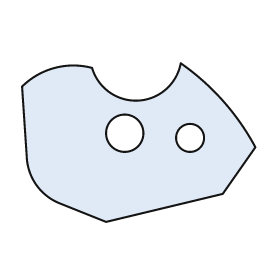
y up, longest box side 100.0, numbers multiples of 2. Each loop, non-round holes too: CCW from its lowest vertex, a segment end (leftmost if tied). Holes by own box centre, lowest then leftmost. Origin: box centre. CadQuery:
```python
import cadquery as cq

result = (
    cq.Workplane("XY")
    .moveTo(-14.0, -34.0)
    .lineTo(36.0, -22.0)
    .lineTo(50.0, -2.0)
    .threePointArc((36.0, 18.0), (18.0, 34.0))
    .threePointArc((0.0, 18.0), (-20.0, 32.0))
    .threePointArc((-36.0, 32.0), (-50.0, 24.0))
    .lineTo(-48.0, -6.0)
    .threePointArc((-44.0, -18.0), (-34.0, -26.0))
    .close()
    .moveTo(22.0, 2.0)
    .circle(6.0)
    .moveTo(-6.0, 4.0)
    .circle(8.0)
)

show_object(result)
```